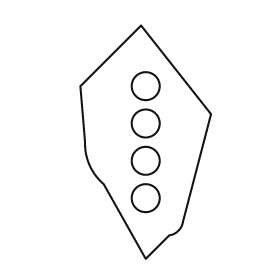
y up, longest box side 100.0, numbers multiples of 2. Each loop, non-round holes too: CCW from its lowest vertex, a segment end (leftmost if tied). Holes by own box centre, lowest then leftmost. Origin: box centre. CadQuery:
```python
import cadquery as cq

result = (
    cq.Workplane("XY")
    .moveTo(0.0, -50.0)
    .lineTo(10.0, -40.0)
    .threePointArc((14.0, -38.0), (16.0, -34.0))
    .lineTo(28.0, 12.0)
    .lineTo(-2.0, 50.0)
    .lineTo(-28.0, 24.0)
    .lineTo(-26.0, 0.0)
    .threePointArc((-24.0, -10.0), (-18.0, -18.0))
    .close()
    .moveTo(0.0, -24.0)
    .circle(6.0)
    .moveTo(0.0, -8.0)
    .circle(6.0)
    .moveTo(0.0, 8.0)
    .circle(6.0)
    .moveTo(0.0, 24.0)
    .circle(6.0)
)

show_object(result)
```